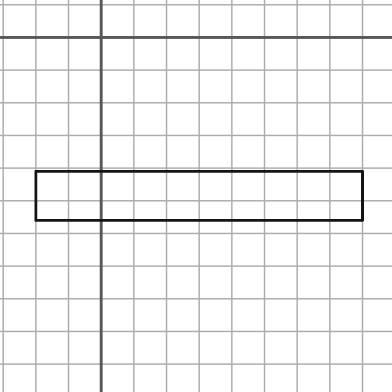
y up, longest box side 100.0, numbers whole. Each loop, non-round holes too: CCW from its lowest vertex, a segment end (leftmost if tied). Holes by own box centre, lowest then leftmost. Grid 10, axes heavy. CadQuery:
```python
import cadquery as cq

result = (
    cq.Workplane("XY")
    .moveTo(-20.0, -56.0)
    .lineTo(80.0, -56.0)
    .lineTo(80.0, -41.0)
    .lineTo(-20.0, -41.0)
    .close()
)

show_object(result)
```